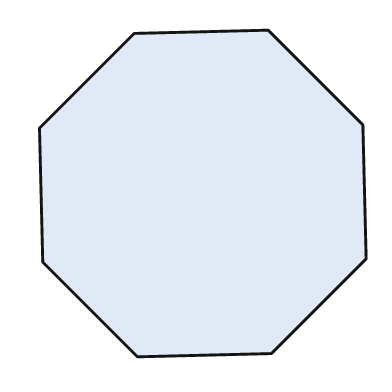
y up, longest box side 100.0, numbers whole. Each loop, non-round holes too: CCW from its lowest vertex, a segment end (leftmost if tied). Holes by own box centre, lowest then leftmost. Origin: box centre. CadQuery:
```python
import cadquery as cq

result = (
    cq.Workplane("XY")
    .moveTo(-20.0, -50.0)
    .lineTo(21.0, -49.0)
    .lineTo(50.0, -20.0)
    .lineTo(49.0, 21.0)
    .lineTo(20.0, 50.0)
    .lineTo(-21.0, 49.0)
    .lineTo(-50.0, 20.0)
    .lineTo(-49.0, -21.0)
    .close()
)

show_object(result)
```